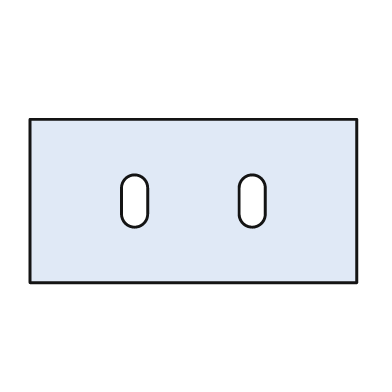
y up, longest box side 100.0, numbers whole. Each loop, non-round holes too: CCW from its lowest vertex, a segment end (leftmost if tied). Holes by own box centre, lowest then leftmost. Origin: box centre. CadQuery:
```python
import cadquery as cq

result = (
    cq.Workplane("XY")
    .moveTo(-50.0, -25.0)
    .lineTo(50.0, -25.0)
    .lineTo(50.0, 25.0)
    .lineTo(-50.0, 25.0)
    .close()
    .moveTo(-22.0, -4.0)
    .threePointArc((-18.0, -8.0), (-14.0, -4.0))
    .lineTo(-14.0, 4.0)
    .threePointArc((-18.0, 8.0), (-22.0, 4.0))
    .close()
    .moveTo(14.0, -4.0)
    .threePointArc((18.0, -8.0), (22.0, -4.0))
    .lineTo(22.0, 4.0)
    .threePointArc((18.0, 8.0), (14.0, 4.0))
    .close()
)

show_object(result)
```